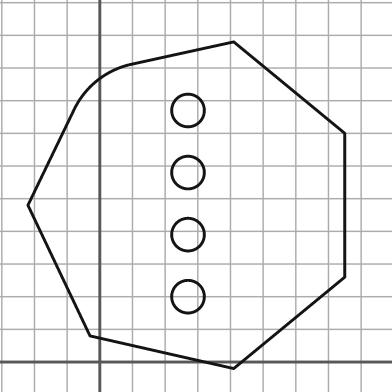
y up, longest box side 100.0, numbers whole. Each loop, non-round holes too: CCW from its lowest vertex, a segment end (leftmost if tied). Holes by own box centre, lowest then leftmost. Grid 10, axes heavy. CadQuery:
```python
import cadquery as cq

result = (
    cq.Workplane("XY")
    .moveTo(41.0, -2.0)
    .lineTo(75.0, 26.0)
    .lineTo(75.0, 70.0)
    .lineTo(41.0, 98.0)
    .lineTo(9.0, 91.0)
    .threePointArc((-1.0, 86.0), (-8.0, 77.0))
    .lineTo(-22.0, 48.0)
    .lineTo(-3.0, 8.0)
    .close()
    .moveTo(27.0, 20.0)
    .circle(5.0)
    .moveTo(27.0, 39.0)
    .circle(5.0)
    .moveTo(27.0, 58.0)
    .circle(5.0)
    .moveTo(27.0, 77.0)
    .circle(5.0)
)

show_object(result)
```